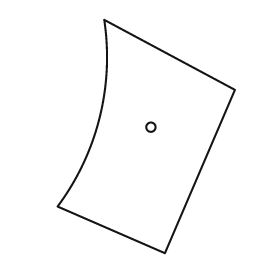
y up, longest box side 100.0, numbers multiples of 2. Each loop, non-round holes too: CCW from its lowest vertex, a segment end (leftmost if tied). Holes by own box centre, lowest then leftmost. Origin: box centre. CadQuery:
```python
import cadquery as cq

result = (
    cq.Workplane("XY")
    .moveTo(8.0, -50.0)
    .lineTo(38.0, 20.0)
    .lineTo(-18.0, 50.0)
    .threePointArc((-20.0, 8.0), (-38.0, -30.0))
    .close()
    .moveTo(2.0, 4.0)
    .circle(2.0)
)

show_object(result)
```